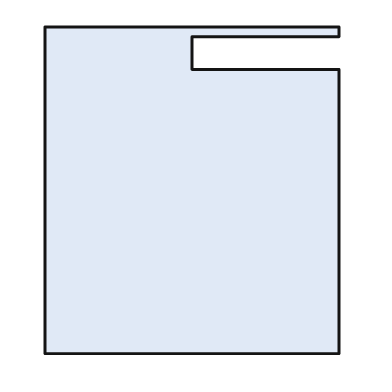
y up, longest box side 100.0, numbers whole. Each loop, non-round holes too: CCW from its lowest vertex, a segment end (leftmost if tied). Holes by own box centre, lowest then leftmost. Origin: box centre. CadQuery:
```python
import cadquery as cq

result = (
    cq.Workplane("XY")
    .moveTo(-45.0, -50.0)
    .lineTo(45.0, -50.0)
    .lineTo(45.0, 37.0)
    .lineTo(0.0, 37.0)
    .lineTo(0.0, 47.0)
    .lineTo(45.0, 47.0)
    .lineTo(45.0, 50.0)
    .lineTo(-45.0, 50.0)
    .close()
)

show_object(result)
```